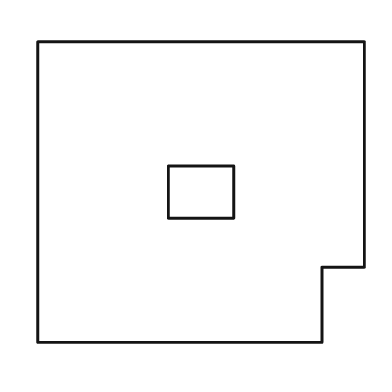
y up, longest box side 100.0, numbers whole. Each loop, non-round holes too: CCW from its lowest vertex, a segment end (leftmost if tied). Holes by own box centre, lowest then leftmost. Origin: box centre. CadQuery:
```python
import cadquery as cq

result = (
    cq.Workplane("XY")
    .moveTo(-50.0, -46.0)
    .lineTo(37.0, -46.0)
    .lineTo(37.0, -23.0)
    .lineTo(50.0, -23.0)
    .lineTo(50.0, 46.0)
    .lineTo(-50.0, 46.0)
    .close()
    .moveTo(-10.0, -8.0)
    .lineTo(10.0, -8.0)
    .lineTo(10.0, 8.0)
    .lineTo(-10.0, 8.0)
    .close()
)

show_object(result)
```